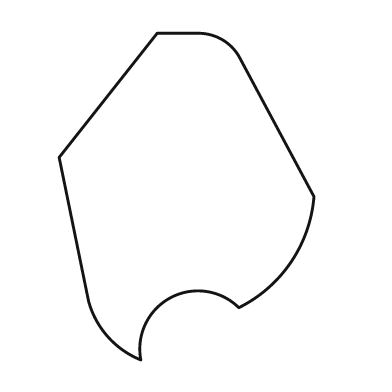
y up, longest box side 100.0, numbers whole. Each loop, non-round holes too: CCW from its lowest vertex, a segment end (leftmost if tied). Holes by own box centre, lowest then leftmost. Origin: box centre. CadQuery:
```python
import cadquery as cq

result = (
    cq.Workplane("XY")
    .moveTo(-14.0, -50.0)
    .threePointArc((-5.0, -31.0), (16.0, -34.0))
    .threePointArc((32.0, -20.0), (39.0, 0.0))
    .lineTo(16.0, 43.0)
    .threePointArc((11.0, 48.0), (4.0, 50.0))
    .lineTo(-9.0, 50.0)
    .lineTo(-39.0, 12.0)
    .lineTo(-30.0, -32.0)
    .threePointArc((-24.0, -43.0), (-14.0, -50.0))
    .close()
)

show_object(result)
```